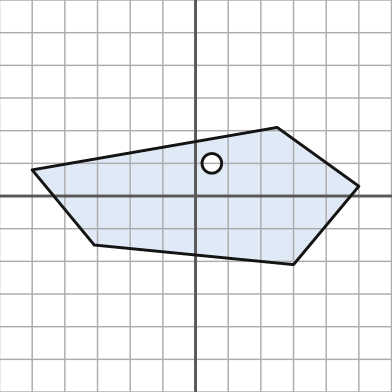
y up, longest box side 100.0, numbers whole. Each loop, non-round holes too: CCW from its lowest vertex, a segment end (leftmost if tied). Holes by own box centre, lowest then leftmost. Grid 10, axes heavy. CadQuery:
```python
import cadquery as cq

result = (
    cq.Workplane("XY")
    .moveTo(30.0, -21.0)
    .lineTo(50.0, 3.0)
    .lineTo(25.0, 21.0)
    .lineTo(-50.0, 8.0)
    .lineTo(-31.0, -15.0)
    .close()
    .moveTo(5.0, 10.0)
    .circle(3.0)
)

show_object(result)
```